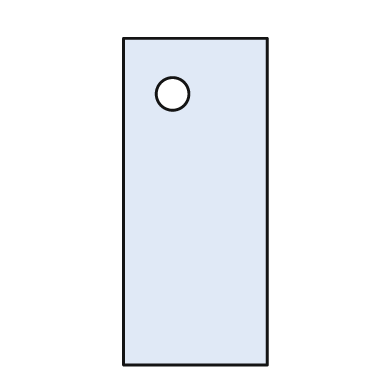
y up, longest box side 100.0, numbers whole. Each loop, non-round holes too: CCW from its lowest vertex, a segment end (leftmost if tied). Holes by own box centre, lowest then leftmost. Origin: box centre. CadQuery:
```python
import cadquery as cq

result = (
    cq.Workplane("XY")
    .moveTo(-22.0, -50.0)
    .lineTo(22.0, -50.0)
    .lineTo(22.0, 50.0)
    .lineTo(-22.0, 50.0)
    .close()
    .moveTo(-7.0, 33.0)
    .circle(5.0)
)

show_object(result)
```